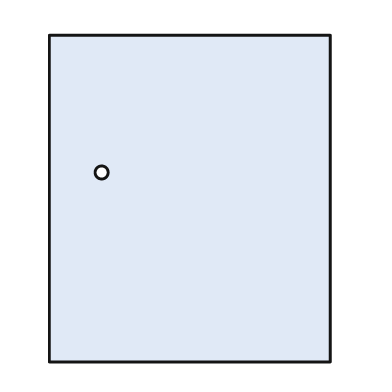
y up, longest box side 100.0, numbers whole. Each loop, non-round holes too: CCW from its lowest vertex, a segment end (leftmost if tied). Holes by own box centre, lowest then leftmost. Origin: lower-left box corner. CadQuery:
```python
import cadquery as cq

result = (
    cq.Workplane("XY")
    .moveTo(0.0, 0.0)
    .lineTo(86.0, 0.0)
    .lineTo(86.0, 100.0)
    .lineTo(0.0, 100.0)
    .close()
    .moveTo(16.0, 58.0)
    .circle(2.0)
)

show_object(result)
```